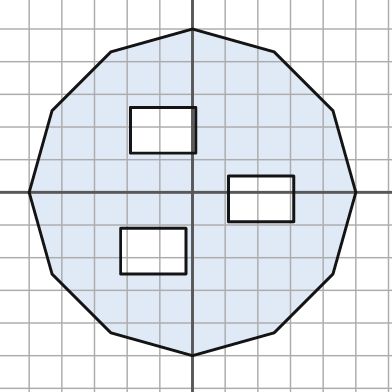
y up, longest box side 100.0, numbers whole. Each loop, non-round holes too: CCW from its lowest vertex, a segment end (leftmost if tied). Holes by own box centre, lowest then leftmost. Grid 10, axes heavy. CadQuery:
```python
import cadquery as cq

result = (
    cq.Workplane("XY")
    .moveTo(0.0, -50.0)
    .lineTo(25.0, -43.0)
    .lineTo(43.0, -25.0)
    .lineTo(50.0, 0.0)
    .lineTo(43.0, 25.0)
    .lineTo(25.0, 43.0)
    .lineTo(0.0, 50.0)
    .lineTo(-25.0, 43.0)
    .lineTo(-43.0, 25.0)
    .lineTo(-50.0, 0.0)
    .lineTo(-43.0, -25.0)
    .lineTo(-25.0, -43.0)
    .close()
    .moveTo(-22.0, -25.0)
    .lineTo(-2.0, -25.0)
    .lineTo(-2.0, -11.0)
    .lineTo(-22.0, -11.0)
    .close()
    .moveTo(11.0, -9.0)
    .lineTo(31.0, -9.0)
    .lineTo(31.0, 5.0)
    .lineTo(11.0, 5.0)
    .close()
    .moveTo(-19.0, 12.0)
    .lineTo(1.0, 12.0)
    .lineTo(1.0, 26.0)
    .lineTo(-19.0, 26.0)
    .close()
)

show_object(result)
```